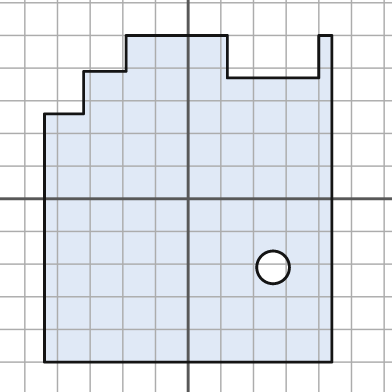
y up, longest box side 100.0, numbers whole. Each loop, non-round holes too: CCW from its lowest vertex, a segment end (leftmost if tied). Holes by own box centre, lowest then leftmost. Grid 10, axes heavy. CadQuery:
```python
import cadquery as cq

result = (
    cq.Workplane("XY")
    .moveTo(-44.0, -50.0)
    .lineTo(44.0, -50.0)
    .lineTo(44.0, 50.0)
    .lineTo(40.0, 50.0)
    .lineTo(40.0, 37.0)
    .lineTo(12.0, 37.0)
    .lineTo(12.0, 50.0)
    .lineTo(-19.0, 50.0)
    .lineTo(-19.0, 39.0)
    .lineTo(-32.0, 39.0)
    .lineTo(-32.0, 26.0)
    .lineTo(-44.0, 26.0)
    .close()
    .moveTo(26.0, -21.0)
    .circle(5.0)
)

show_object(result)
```